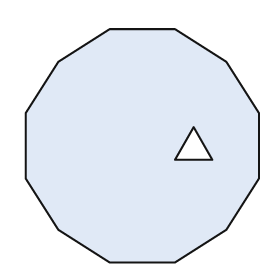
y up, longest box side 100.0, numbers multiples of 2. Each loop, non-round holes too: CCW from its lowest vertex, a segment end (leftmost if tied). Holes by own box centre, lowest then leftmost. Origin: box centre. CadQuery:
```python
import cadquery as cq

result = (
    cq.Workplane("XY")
    .moveTo(-14.0, -50.0)
    .lineTo(14.0, -50.0)
    .lineTo(36.0, -36.0)
    .lineTo(50.0, -14.0)
    .lineTo(50.0, 14.0)
    .lineTo(36.0, 36.0)
    .lineTo(14.0, 50.0)
    .lineTo(-14.0, 50.0)
    .lineTo(-36.0, 36.0)
    .lineTo(-50.0, 14.0)
    .lineTo(-50.0, -14.0)
    .lineTo(-36.0, -36.0)
    .close()
    .moveTo(14.0, -6.0)
    .lineTo(30.0, -6.0)
    .lineTo(22.0, 8.0)
    .close()
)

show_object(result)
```